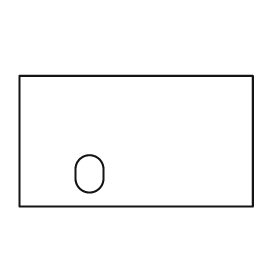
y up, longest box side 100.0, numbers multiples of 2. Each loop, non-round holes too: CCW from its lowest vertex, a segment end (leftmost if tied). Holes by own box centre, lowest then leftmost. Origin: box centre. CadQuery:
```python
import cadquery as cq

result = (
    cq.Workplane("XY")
    .moveTo(-50.0, -28.0)
    .lineTo(50.0, -28.0)
    .lineTo(50.0, 28.0)
    .lineTo(-50.0, 28.0)
    .close()
    .moveTo(-26.0, -16.0)
    .threePointArc((-20.0, -22.0), (-14.0, -16.0))
    .lineTo(-14.0, -12.0)
    .threePointArc((-20.0, -6.0), (-26.0, -12.0))
    .close()
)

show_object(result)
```